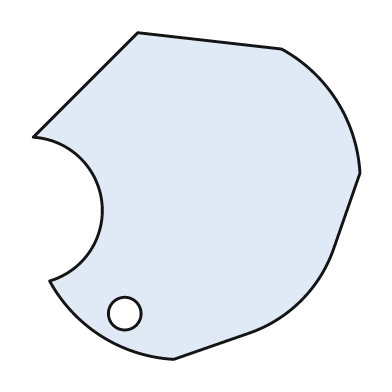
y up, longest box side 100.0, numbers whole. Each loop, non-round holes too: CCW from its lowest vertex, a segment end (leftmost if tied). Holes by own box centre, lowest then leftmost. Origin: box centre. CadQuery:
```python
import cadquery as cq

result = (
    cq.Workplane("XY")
    .moveTo(-7.0, -50.0)
    .lineTo(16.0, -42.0)
    .threePointArc((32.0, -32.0), (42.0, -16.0))
    .lineTo(50.0, 7.0)
    .threePointArc((43.0, 29.0), (26.0, 45.0))
    .lineTo(-18.0, 50.0)
    .lineTo(-50.0, 18.0)
    .threePointArc((-29.0, -2.0), (-45.0, -26.0))
    .threePointArc((-29.0, -43.0), (-7.0, -50.0))
    .close()
    .moveTo(-22.0, -36.0)
    .circle(5.0)
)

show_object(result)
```